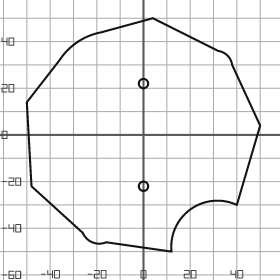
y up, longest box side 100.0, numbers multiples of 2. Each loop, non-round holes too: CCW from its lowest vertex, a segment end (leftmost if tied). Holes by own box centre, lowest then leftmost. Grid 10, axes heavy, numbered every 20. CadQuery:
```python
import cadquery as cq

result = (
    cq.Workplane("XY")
    .moveTo(12.0, -50.0)
    .threePointArc((20.0, -32.0), (40.0, -30.0))
    .lineTo(50.0, 4.0)
    .lineTo(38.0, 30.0)
    .threePointArc((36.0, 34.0), (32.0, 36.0))
    .lineTo(4.0, 50.0)
    .lineTo(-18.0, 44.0)
    .threePointArc((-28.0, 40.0), (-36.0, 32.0))
    .lineTo(-50.0, 14.0)
    .lineTo(-48.0, -22.0)
    .lineTo(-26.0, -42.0)
    .threePointArc((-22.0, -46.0), (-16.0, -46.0))
    .close()
    .moveTo(0.0, -22.0)
    .circle(2.0)
    .moveTo(0.0, 22.0)
    .circle(2.0)
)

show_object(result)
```